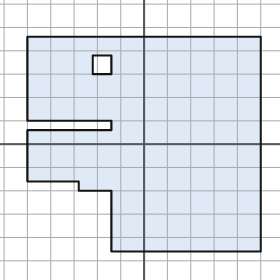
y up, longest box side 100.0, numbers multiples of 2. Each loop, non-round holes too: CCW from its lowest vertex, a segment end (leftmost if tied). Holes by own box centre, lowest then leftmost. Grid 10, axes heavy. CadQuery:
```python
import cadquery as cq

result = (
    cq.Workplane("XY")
    .moveTo(-14.0, -46.0)
    .lineTo(50.0, -46.0)
    .lineTo(50.0, 46.0)
    .lineTo(-50.0, 46.0)
    .lineTo(-50.0, 10.0)
    .lineTo(-14.0, 10.0)
    .lineTo(-14.0, 6.0)
    .lineTo(-50.0, 6.0)
    .lineTo(-50.0, -16.0)
    .lineTo(-28.0, -16.0)
    .lineTo(-28.0, -20.0)
    .lineTo(-14.0, -20.0)
    .close()
    .moveTo(-22.0, 30.0)
    .lineTo(-14.0, 30.0)
    .lineTo(-14.0, 38.0)
    .lineTo(-22.0, 38.0)
    .close()
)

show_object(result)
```